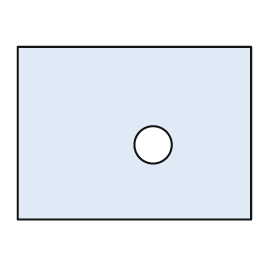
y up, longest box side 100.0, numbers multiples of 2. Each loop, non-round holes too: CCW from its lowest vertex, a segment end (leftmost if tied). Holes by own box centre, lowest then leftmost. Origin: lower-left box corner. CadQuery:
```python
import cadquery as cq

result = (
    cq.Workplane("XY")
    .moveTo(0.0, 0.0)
    .lineTo(100.0, 0.0)
    .lineTo(100.0, 74.0)
    .lineTo(0.0, 74.0)
    .close()
    .moveTo(58.0, 32.0)
    .circle(8.0)
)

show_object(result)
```